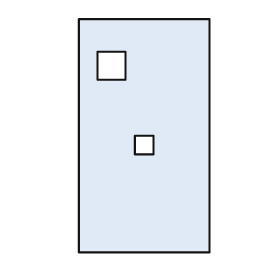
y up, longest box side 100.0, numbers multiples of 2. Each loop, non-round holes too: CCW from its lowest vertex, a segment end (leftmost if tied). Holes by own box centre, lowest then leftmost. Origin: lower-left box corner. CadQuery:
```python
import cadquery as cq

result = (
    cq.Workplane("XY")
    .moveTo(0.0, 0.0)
    .lineTo(56.0, 0.0)
    .lineTo(56.0, 100.0)
    .lineTo(0.0, 100.0)
    .close()
    .moveTo(24.0, 42.0)
    .lineTo(32.0, 42.0)
    .lineTo(32.0, 50.0)
    .lineTo(24.0, 50.0)
    .close()
    .moveTo(8.0, 74.0)
    .lineTo(20.0, 74.0)
    .lineTo(20.0, 86.0)
    .lineTo(8.0, 86.0)
    .close()
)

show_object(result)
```